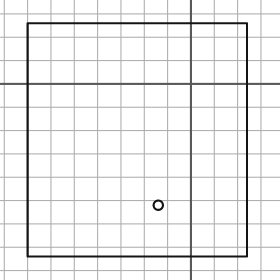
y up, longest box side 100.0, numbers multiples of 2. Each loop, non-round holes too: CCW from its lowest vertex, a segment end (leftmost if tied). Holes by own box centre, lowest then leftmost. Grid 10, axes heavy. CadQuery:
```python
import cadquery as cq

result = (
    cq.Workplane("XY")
    .moveTo(-70.0, -74.0)
    .lineTo(24.0, -74.0)
    .lineTo(24.0, 26.0)
    .lineTo(-70.0, 26.0)
    .close()
    .moveTo(-14.0, -52.0)
    .circle(2.0)
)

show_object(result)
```